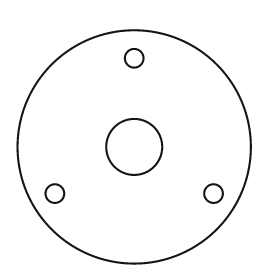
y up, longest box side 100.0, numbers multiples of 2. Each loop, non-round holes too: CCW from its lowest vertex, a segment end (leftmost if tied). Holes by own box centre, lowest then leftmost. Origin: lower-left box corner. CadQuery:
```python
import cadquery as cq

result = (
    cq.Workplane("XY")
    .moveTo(50.0, 50.0)
    .circle(50.0)
    .moveTo(16.0, 30.0)
    .circle(4.0)
    .moveTo(84.0, 30.0)
    .circle(4.0)
    .moveTo(50.0, 50.0)
    .circle(12.0)
    .moveTo(50.0, 88.0)
    .circle(4.0)
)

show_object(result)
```